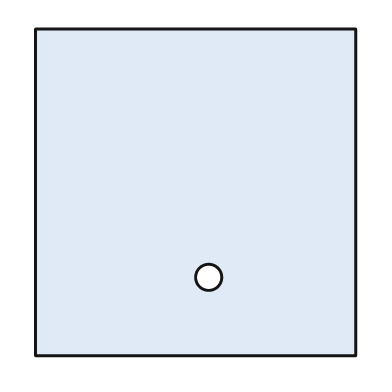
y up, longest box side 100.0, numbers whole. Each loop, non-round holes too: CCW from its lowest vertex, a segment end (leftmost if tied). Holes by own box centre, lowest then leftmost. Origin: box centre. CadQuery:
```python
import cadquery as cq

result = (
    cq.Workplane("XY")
    .moveTo(-49.0, -50.0)
    .lineTo(49.0, -50.0)
    .lineTo(49.0, 50.0)
    .lineTo(-49.0, 50.0)
    .close()
    .moveTo(4.0, -26.0)
    .circle(4.0)
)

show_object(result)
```